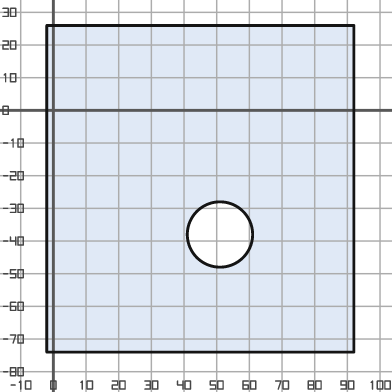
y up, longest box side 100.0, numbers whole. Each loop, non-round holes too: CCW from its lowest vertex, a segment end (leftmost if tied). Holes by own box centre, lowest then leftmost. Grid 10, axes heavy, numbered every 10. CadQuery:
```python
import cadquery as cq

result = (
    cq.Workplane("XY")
    .moveTo(-2.0, -74.0)
    .lineTo(92.0, -74.0)
    .lineTo(92.0, 26.0)
    .lineTo(-2.0, 26.0)
    .close()
    .moveTo(51.0, -38.0)
    .circle(10.0)
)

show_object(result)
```